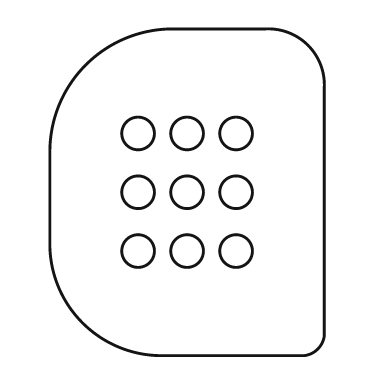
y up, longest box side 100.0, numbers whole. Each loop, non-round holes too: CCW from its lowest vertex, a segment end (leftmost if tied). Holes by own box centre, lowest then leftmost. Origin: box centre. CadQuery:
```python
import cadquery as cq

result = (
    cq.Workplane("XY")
    .moveTo(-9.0, -50.0)
    .lineTo(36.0, -50.0)
    .threePointArc((40.0, -48.0), (42.0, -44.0))
    .lineTo(42.0, 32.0)
    .threePointArc((37.0, 45.0), (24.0, 50.0))
    .lineTo(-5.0, 50.0)
    .threePointArc((-31.0, 39.0), (-42.0, 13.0))
    .lineTo(-42.0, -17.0)
    .threePointArc((-32.0, -40.0), (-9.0, -50.0))
    .close()
    .moveTo(-15.0, -18.0)
    .circle(5.0)
    .moveTo(0.0, -18.0)
    .circle(5.0)
    .moveTo(15.0, -18.0)
    .circle(5.0)
    .moveTo(-15.0, 0.0)
    .circle(5.0)
    .moveTo(0.0, 0.0)
    .circle(5.0)
    .moveTo(15.0, 0.0)
    .circle(5.0)
    .moveTo(-15.0, 18.0)
    .circle(5.0)
    .moveTo(0.0, 18.0)
    .circle(5.0)
    .moveTo(15.0, 18.0)
    .circle(5.0)
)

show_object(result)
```